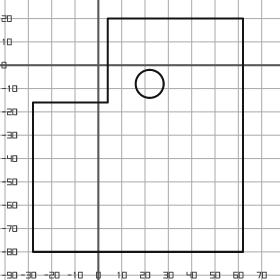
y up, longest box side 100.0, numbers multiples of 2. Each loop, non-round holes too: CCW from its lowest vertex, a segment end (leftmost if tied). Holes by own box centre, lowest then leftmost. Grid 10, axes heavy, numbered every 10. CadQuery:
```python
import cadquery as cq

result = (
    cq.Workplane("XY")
    .moveTo(-28.0, -80.0)
    .lineTo(62.0, -80.0)
    .lineTo(62.0, 20.0)
    .lineTo(4.0, 20.0)
    .lineTo(4.0, -16.0)
    .lineTo(-28.0, -16.0)
    .close()
    .moveTo(22.0, -8.0)
    .circle(6.0)
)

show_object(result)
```